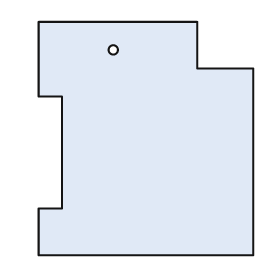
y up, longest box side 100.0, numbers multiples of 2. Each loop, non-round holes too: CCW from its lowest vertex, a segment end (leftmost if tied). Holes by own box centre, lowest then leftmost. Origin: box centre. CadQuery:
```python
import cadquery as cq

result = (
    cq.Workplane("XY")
    .moveTo(-46.0, -50.0)
    .lineTo(46.0, -50.0)
    .lineTo(46.0, 30.0)
    .lineTo(22.0, 30.0)
    .lineTo(22.0, 50.0)
    .lineTo(-46.0, 50.0)
    .lineTo(-46.0, 18.0)
    .lineTo(-36.0, 18.0)
    .lineTo(-36.0, -30.0)
    .lineTo(-46.0, -30.0)
    .close()
    .moveTo(-14.0, 38.0)
    .circle(2.0)
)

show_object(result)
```